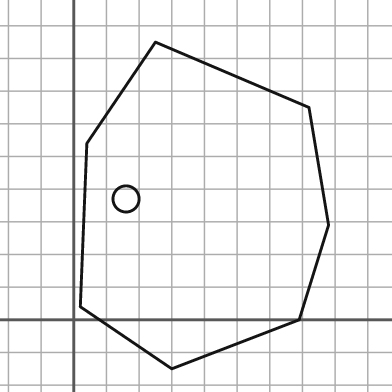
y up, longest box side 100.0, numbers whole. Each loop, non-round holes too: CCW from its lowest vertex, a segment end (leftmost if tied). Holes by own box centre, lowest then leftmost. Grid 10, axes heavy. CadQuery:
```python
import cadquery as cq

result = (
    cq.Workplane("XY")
    .moveTo(30.0, -15.0)
    .lineTo(69.0, 0.0)
    .lineTo(78.0, 29.0)
    .lineTo(72.0, 65.0)
    .lineTo(25.0, 85.0)
    .lineTo(4.0, 54.0)
    .lineTo(2.0, 4.0)
    .close()
    .moveTo(16.0, 37.0)
    .circle(4.0)
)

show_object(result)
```